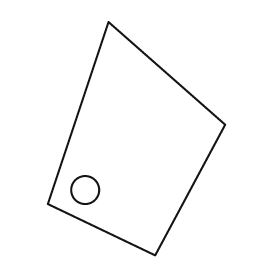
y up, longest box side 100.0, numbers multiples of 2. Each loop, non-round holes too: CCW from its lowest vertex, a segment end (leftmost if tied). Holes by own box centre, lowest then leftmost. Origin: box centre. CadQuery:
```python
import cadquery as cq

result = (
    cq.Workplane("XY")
    .moveTo(8.0, -50.0)
    .lineTo(38.0, 6.0)
    .lineTo(-12.0, 50.0)
    .lineTo(-38.0, -28.0)
    .close()
    .moveTo(-22.0, -22.0)
    .circle(6.0)
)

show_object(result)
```